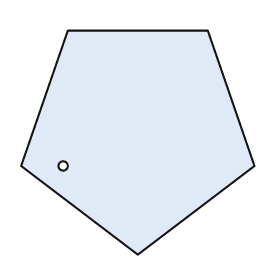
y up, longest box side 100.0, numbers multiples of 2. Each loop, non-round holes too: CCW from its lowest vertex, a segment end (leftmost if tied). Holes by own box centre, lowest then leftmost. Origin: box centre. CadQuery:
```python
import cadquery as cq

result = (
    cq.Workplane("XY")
    .moveTo(0.0, -48.0)
    .lineTo(50.0, -10.0)
    .lineTo(30.0, 48.0)
    .lineTo(-30.0, 48.0)
    .lineTo(-50.0, -10.0)
    .close()
    .moveTo(-32.0, -10.0)
    .circle(2.0)
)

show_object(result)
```